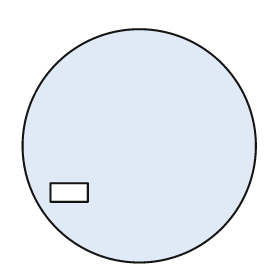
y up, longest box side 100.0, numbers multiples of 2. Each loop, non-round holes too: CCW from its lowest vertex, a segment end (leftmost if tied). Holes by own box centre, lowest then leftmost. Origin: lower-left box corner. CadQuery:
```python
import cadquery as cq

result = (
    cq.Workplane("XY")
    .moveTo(50.0, 50.0)
    .circle(50.0)
    .moveTo(12.0, 26.0)
    .lineTo(28.0, 26.0)
    .lineTo(28.0, 34.0)
    .lineTo(12.0, 34.0)
    .close()
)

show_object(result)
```